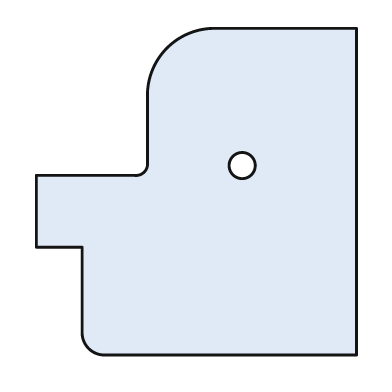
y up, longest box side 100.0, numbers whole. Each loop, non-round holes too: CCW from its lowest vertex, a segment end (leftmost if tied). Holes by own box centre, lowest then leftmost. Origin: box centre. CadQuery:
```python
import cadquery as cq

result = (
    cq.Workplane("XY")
    .moveTo(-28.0, -50.0)
    .lineTo(49.0, -50.0)
    .lineTo(49.0, 50.0)
    .lineTo(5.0, 50.0)
    .threePointArc((-9.0, 44.0), (-15.0, 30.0))
    .lineTo(-15.0, 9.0)
    .threePointArc((-16.0, 6.0), (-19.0, 5.0))
    .lineTo(-49.0, 5.0)
    .lineTo(-49.0, -17.0)
    .lineTo(-35.0, -17.0)
    .lineTo(-35.0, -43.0)
    .threePointArc((-33.0, -48.0), (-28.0, -50.0))
    .close()
    .moveTo(14.0, 8.0)
    .circle(4.0)
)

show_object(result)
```